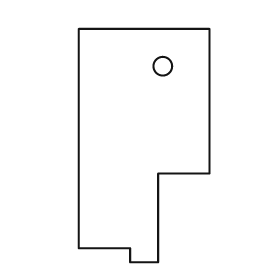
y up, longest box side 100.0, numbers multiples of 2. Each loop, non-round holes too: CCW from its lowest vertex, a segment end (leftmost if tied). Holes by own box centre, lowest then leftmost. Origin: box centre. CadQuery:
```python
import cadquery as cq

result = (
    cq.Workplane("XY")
    .moveTo(-6.0, -50.0)
    .lineTo(6.0, -50.0)
    .lineTo(6.0, -12.0)
    .lineTo(28.0, -12.0)
    .lineTo(28.0, 50.0)
    .lineTo(-28.0, 50.0)
    .lineTo(-28.0, -44.0)
    .lineTo(-6.0, -44.0)
    .close()
    .moveTo(8.0, 34.0)
    .circle(4.0)
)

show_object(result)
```